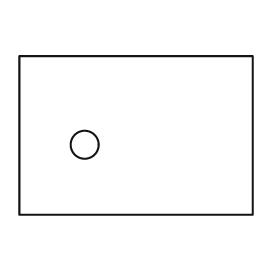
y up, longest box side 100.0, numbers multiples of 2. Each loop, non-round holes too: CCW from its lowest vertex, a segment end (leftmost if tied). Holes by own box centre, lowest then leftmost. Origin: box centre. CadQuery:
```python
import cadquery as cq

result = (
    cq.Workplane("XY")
    .moveTo(-50.0, -34.0)
    .lineTo(50.0, -34.0)
    .lineTo(50.0, 34.0)
    .lineTo(-50.0, 34.0)
    .close()
    .moveTo(-22.0, -4.0)
    .circle(6.0)
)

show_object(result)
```